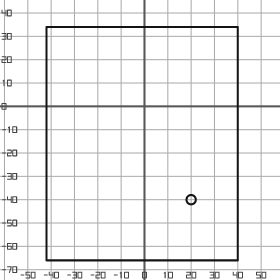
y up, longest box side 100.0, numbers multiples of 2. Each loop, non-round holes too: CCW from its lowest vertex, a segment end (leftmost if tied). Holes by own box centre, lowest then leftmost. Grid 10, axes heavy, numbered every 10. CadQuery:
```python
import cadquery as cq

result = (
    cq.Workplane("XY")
    .moveTo(-42.0, -66.0)
    .lineTo(40.0, -66.0)
    .lineTo(40.0, 34.0)
    .lineTo(-42.0, 34.0)
    .close()
    .moveTo(20.0, -40.0)
    .circle(2.0)
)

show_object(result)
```